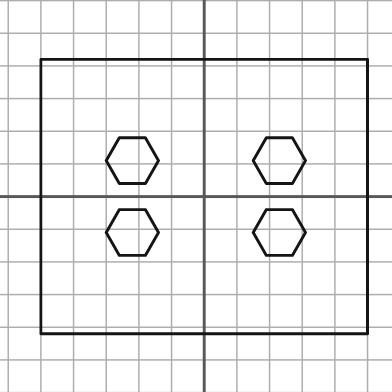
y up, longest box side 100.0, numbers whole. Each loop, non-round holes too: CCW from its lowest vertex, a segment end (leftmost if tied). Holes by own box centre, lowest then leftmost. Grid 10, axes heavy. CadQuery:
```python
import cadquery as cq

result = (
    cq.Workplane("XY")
    .moveTo(-50.0, -42.0)
    .lineTo(50.0, -42.0)
    .lineTo(50.0, 42.0)
    .lineTo(-50.0, 42.0)
    .close()
    .moveTo(-26.0, -18.0)
    .lineTo(-18.0, -18.0)
    .lineTo(-14.0, -11.0)
    .lineTo(-18.0, -4.0)
    .lineTo(-26.0, -4.0)
    .lineTo(-30.0, -11.0)
    .close()
    .moveTo(19.0, -18.0)
    .lineTo(27.0, -18.0)
    .lineTo(31.0, -11.0)
    .lineTo(27.0, -4.0)
    .lineTo(19.0, -4.0)
    .lineTo(15.0, -11.0)
    .close()
    .moveTo(-26.0, 4.0)
    .lineTo(-18.0, 4.0)
    .lineTo(-14.0, 11.0)
    .lineTo(-18.0, 18.0)
    .lineTo(-26.0, 18.0)
    .lineTo(-30.0, 11.0)
    .close()
    .moveTo(19.0, 4.0)
    .lineTo(27.0, 4.0)
    .lineTo(31.0, 11.0)
    .lineTo(27.0, 18.0)
    .lineTo(19.0, 18.0)
    .lineTo(15.0, 11.0)
    .close()
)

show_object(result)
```